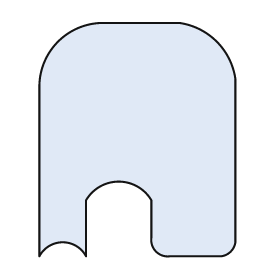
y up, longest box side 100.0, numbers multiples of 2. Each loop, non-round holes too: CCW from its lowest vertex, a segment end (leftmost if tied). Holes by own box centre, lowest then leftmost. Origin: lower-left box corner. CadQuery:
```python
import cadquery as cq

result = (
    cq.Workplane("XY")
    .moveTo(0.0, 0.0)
    .threePointArc((10.0, 6.0), (20.0, 0.0))
    .lineTo(20.0, 24.0)
    .threePointArc((34.0, 32.0), (48.0, 24.0))
    .lineTo(48.0, 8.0)
    .threePointArc((50.0, 2.0), (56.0, 0.0))
    .lineTo(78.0, 0.0)
    .threePointArc((82.0, 2.0), (84.0, 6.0))
    .lineTo(84.0, 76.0)
    .threePointArc((76.0, 92.0), (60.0, 100.0))
    .lineTo(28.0, 100.0)
    .threePointArc((8.0, 92.0), (0.0, 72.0))
    .close()
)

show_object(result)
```